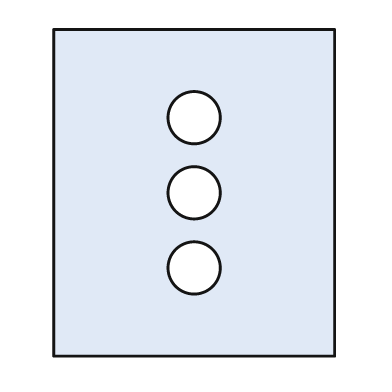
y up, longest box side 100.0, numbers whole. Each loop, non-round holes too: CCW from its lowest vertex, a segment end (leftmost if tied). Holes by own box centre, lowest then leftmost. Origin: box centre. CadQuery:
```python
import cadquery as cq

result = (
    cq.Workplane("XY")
    .moveTo(-43.0, -50.0)
    .lineTo(43.0, -50.0)
    .lineTo(43.0, 50.0)
    .lineTo(-43.0, 50.0)
    .close()
    .moveTo(0.0, -23.0)
    .circle(8.0)
    .moveTo(0.0, 0.0)
    .circle(8.0)
    .moveTo(0.0, 23.0)
    .circle(8.0)
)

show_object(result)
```